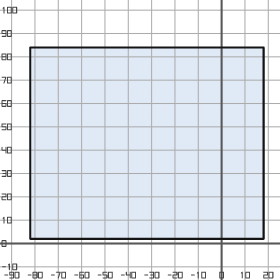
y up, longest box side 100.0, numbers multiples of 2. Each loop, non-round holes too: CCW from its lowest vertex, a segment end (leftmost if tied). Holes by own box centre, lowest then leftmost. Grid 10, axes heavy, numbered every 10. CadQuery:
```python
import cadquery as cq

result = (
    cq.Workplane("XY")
    .moveTo(-82.0, 2.0)
    .lineTo(18.0, 2.0)
    .lineTo(18.0, 84.0)
    .lineTo(-82.0, 84.0)
    .close()
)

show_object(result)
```